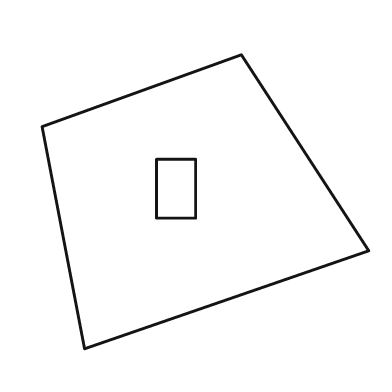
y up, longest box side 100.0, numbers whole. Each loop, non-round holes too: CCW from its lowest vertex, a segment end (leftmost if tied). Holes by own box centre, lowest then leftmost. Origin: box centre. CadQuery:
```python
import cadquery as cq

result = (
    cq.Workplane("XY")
    .moveTo(-37.0, -45.0)
    .lineTo(50.0, -15.0)
    .lineTo(11.0, 45.0)
    .lineTo(-50.0, 23.0)
    .close()
    .moveTo(-15.0, -5.0)
    .lineTo(-3.0, -5.0)
    .lineTo(-3.0, 13.0)
    .lineTo(-15.0, 13.0)
    .close()
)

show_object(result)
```